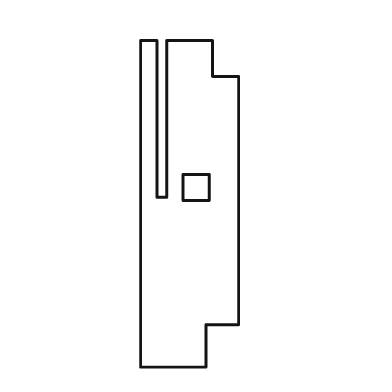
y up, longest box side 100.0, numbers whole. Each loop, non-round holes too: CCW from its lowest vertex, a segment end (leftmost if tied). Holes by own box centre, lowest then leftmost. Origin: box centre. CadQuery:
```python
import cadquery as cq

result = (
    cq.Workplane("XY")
    .moveTo(-15.0, -50.0)
    .lineTo(5.0, -50.0)
    .lineTo(5.0, -37.0)
    .lineTo(15.0, -37.0)
    .lineTo(15.0, 39.0)
    .lineTo(7.0, 39.0)
    .lineTo(7.0, 50.0)
    .lineTo(-7.0, 50.0)
    .lineTo(-7.0, 2.0)
    .lineTo(-10.0, 2.0)
    .lineTo(-10.0, 50.0)
    .lineTo(-15.0, 50.0)
    .close()
    .moveTo(-2.0, 1.0)
    .lineTo(6.0, 1.0)
    .lineTo(6.0, 9.0)
    .lineTo(-2.0, 9.0)
    .close()
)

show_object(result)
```